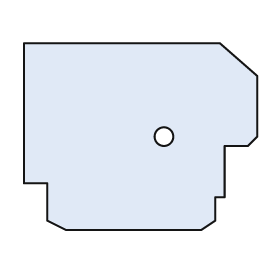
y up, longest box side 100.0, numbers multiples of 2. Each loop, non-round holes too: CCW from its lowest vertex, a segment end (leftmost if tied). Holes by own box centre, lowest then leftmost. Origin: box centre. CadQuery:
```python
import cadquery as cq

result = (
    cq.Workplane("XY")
    .moveTo(-32.0, -40.0)
    .lineTo(26.0, -40.0)
    .lineTo(32.0, -36.0)
    .lineTo(32.0, -26.0)
    .lineTo(36.0, -26.0)
    .lineTo(36.0, -4.0)
    .lineTo(46.0, -4.0)
    .lineTo(50.0, 0.0)
    .lineTo(50.0, 26.0)
    .lineTo(34.0, 40.0)
    .lineTo(-50.0, 40.0)
    .lineTo(-50.0, -20.0)
    .lineTo(-40.0, -20.0)
    .lineTo(-40.0, -36.0)
    .close()
    .moveTo(10.0, 0.0)
    .circle(4.0)
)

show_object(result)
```